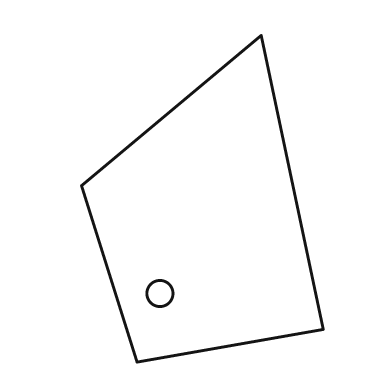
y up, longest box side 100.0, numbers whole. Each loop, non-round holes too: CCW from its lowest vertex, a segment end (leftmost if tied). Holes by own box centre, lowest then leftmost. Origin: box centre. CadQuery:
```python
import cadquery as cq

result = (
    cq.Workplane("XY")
    .moveTo(-20.0, -50.0)
    .lineTo(37.0, -40.0)
    .lineTo(18.0, 50.0)
    .lineTo(-37.0, 4.0)
    .close()
    .moveTo(-13.0, -29.0)
    .circle(4.0)
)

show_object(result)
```